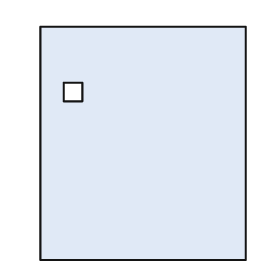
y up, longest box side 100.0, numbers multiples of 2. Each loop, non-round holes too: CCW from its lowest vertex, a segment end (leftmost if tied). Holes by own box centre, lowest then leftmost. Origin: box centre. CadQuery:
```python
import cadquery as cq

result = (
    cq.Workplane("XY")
    .moveTo(-44.0, -50.0)
    .lineTo(44.0, -50.0)
    .lineTo(44.0, 50.0)
    .lineTo(-44.0, 50.0)
    .close()
    .moveTo(-34.0, 18.0)
    .lineTo(-26.0, 18.0)
    .lineTo(-26.0, 26.0)
    .lineTo(-34.0, 26.0)
    .close()
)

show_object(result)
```